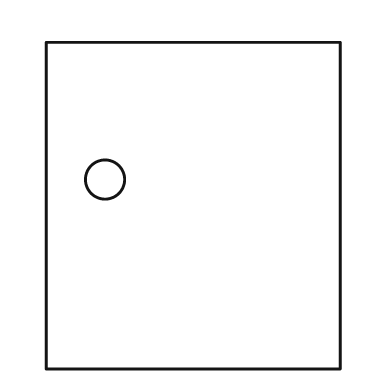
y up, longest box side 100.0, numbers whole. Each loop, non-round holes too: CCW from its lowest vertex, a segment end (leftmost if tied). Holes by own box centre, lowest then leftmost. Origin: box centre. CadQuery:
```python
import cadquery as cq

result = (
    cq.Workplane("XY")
    .moveTo(-45.0, -50.0)
    .lineTo(45.0, -50.0)
    .lineTo(45.0, 50.0)
    .lineTo(-45.0, 50.0)
    .close()
    .moveTo(-27.0, 8.0)
    .circle(6.0)
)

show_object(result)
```